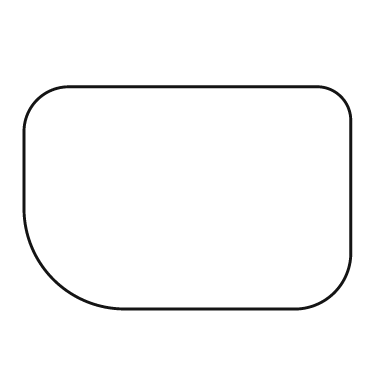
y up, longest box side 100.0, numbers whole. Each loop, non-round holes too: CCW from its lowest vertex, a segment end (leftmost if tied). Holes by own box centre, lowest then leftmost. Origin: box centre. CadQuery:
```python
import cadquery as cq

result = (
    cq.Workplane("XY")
    .moveTo(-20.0, -34.0)
    .lineTo(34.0, -34.0)
    .threePointArc((45.0, -29.0), (50.0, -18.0))
    .lineTo(50.0, 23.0)
    .threePointArc((47.0, 31.0), (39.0, 34.0))
    .lineTo(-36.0, 34.0)
    .threePointArc((-46.0, 30.0), (-50.0, 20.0))
    .lineTo(-50.0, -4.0)
    .threePointArc((-41.0, -25.0), (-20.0, -34.0))
    .close()
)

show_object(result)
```